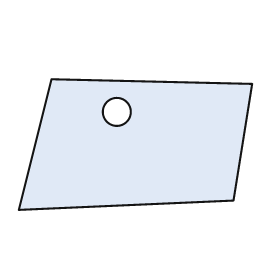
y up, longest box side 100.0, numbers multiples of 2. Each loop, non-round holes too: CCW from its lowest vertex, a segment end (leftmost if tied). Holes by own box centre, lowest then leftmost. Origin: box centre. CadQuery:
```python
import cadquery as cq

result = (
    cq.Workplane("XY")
    .moveTo(-50.0, -28.0)
    .lineTo(42.0, -24.0)
    .lineTo(50.0, 26.0)
    .lineTo(-36.0, 28.0)
    .close()
    .moveTo(-8.0, 14.0)
    .circle(6.0)
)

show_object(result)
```